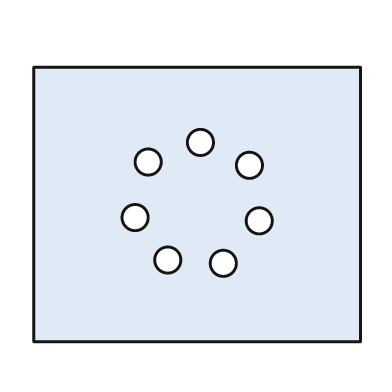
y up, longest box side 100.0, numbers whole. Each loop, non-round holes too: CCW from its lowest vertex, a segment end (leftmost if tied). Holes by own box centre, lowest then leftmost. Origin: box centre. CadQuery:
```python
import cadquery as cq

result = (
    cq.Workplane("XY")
    .moveTo(-50.0, -42.0)
    .lineTo(50.0, -42.0)
    .lineTo(50.0, 42.0)
    .lineTo(-50.0, 42.0)
    .close()
    .moveTo(8.0, -18.0)
    .circle(4.0)
    .moveTo(-9.0, -17.0)
    .circle(4.0)
    .moveTo(19.0, -5.0)
    .circle(4.0)
    .moveTo(-19.0, -4.0)
    .circle(4.0)
    .moveTo(16.0, 12.0)
    .circle(4.0)
    .moveTo(-15.0, 13.0)
    .circle(4.0)
    .moveTo(1.0, 19.0)
    .circle(4.0)
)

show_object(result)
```